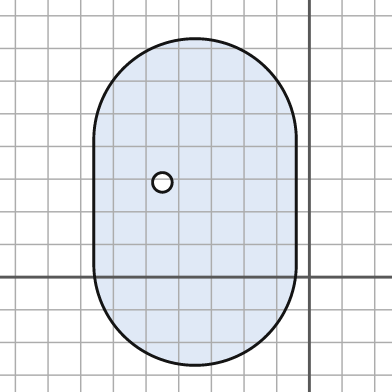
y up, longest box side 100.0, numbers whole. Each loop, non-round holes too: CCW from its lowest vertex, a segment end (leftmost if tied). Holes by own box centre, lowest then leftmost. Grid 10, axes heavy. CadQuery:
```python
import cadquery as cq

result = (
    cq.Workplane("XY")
    .moveTo(-66.0, 4.0)
    .threePointArc((-35.0, -27.0), (-4.0, 4.0))
    .lineTo(-4.0, 42.0)
    .threePointArc((-35.0, 73.0), (-66.0, 42.0))
    .close()
    .moveTo(-45.0, 29.0)
    .circle(3.0)
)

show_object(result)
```